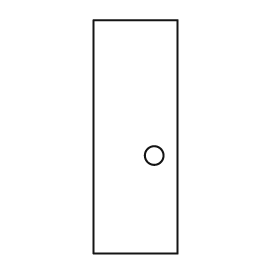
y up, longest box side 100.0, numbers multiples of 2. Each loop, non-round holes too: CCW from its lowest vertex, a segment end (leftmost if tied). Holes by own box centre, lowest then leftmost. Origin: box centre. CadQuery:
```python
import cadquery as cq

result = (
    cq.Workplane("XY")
    .moveTo(-18.0, -50.0)
    .lineTo(18.0, -50.0)
    .lineTo(18.0, 50.0)
    .lineTo(-18.0, 50.0)
    .close()
    .moveTo(8.0, -8.0)
    .circle(4.0)
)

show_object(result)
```